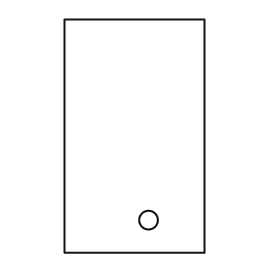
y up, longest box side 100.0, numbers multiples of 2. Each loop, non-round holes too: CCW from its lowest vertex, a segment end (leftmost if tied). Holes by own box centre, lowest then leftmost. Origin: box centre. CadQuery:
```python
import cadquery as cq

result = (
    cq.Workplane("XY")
    .moveTo(-30.0, -50.0)
    .lineTo(30.0, -50.0)
    .lineTo(30.0, 50.0)
    .lineTo(-30.0, 50.0)
    .close()
    .moveTo(6.0, -36.0)
    .circle(4.0)
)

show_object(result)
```